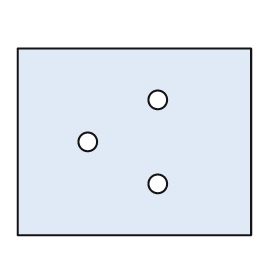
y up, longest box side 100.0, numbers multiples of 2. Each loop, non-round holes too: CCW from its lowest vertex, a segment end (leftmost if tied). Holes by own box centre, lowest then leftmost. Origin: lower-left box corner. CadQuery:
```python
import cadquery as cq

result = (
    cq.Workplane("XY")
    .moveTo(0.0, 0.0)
    .lineTo(100.0, 0.0)
    .lineTo(100.0, 80.0)
    .lineTo(0.0, 80.0)
    .close()
    .moveTo(60.0, 22.0)
    .circle(4.0)
    .moveTo(30.0, 40.0)
    .circle(4.0)
    .moveTo(60.0, 58.0)
    .circle(4.0)
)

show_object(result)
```